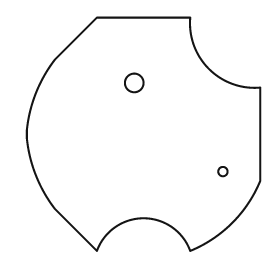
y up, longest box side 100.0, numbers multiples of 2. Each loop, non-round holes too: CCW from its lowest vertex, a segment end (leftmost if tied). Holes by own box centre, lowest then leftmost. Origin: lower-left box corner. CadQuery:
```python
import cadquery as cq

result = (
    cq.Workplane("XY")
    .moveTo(30.0, 0.0)
    .threePointArc((50.0, 14.0), (70.0, 0.0))
    .threePointArc((88.0, 12.0), (100.0, 30.0))
    .lineTo(100.0, 70.0)
    .threePointArc((78.0, 78.0), (70.0, 100.0))
    .lineTo(30.0, 100.0)
    .lineTo(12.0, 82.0)
    .threePointArc((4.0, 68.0), (0.0, 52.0))
    .lineTo(0.0, 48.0)
    .threePointArc((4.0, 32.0), (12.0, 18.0))
    .close()
    .moveTo(84.0, 34.0)
    .circle(2.0)
    .moveTo(46.0, 72.0)
    .circle(4.0)
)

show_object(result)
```